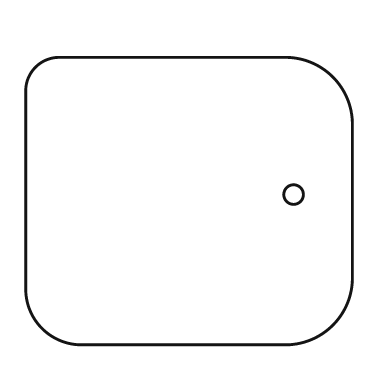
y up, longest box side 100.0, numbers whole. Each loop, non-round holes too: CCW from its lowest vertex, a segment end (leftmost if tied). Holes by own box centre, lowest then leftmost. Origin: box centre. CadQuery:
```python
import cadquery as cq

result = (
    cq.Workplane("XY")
    .moveTo(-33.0, -44.0)
    .lineTo(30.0, -44.0)
    .threePointArc((44.0, -38.0), (50.0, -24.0))
    .lineTo(50.0, 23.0)
    .threePointArc((44.0, 38.0), (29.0, 44.0))
    .lineTo(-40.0, 44.0)
    .threePointArc((-47.0, 41.0), (-50.0, 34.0))
    .lineTo(-50.0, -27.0)
    .threePointArc((-45.0, -39.0), (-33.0, -44.0))
    .close()
    .moveTo(32.0, 2.0)
    .circle(3.0)
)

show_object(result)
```